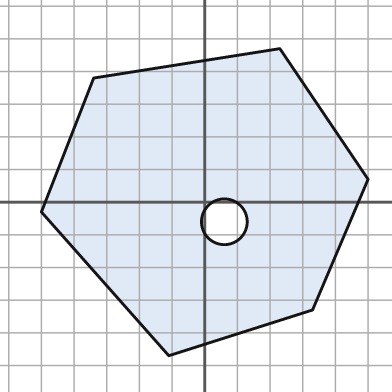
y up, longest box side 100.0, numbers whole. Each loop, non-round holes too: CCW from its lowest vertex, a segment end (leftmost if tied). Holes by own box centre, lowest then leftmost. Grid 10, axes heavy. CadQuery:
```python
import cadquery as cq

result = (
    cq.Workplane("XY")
    .moveTo(-11.0, -47.0)
    .lineTo(33.0, -33.0)
    .lineTo(50.0, 7.0)
    .lineTo(23.0, 47.0)
    .lineTo(-34.0, 38.0)
    .lineTo(-50.0, -3.0)
    .close()
    .moveTo(6.0, -6.0)
    .circle(7.0)
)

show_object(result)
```